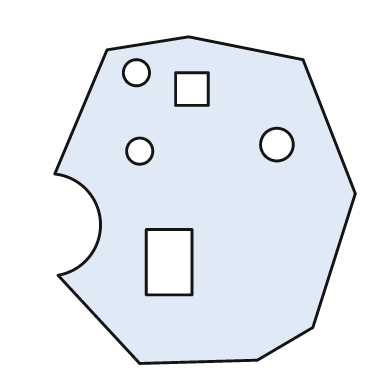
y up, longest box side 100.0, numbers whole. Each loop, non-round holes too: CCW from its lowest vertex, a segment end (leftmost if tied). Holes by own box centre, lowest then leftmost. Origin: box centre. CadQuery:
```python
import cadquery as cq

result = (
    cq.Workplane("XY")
    .moveTo(-20.0, -50.0)
    .lineTo(16.0, -49.0)
    .lineTo(33.0, -39.0)
    .lineTo(46.0, 2.0)
    .lineTo(30.0, 43.0)
    .lineTo(-5.0, 50.0)
    .lineTo(-30.0, 46.0)
    .lineTo(-46.0, 8.0)
    .threePointArc((-32.0, -7.0), (-45.0, -23.0))
    .close()
    .moveTo(-18.0, -29.0)
    .lineTo(-4.0, -29.0)
    .lineTo(-4.0, -9.0)
    .lineTo(-18.0, -9.0)
    .close()
    .moveTo(-20.0, 15.0)
    .circle(4.0)
    .moveTo(22.0, 17.0)
    .circle(5.0)
    .moveTo(-9.0, 29.0)
    .lineTo(1.0, 29.0)
    .lineTo(1.0, 39.0)
    .lineTo(-9.0, 39.0)
    .close()
    .moveTo(-21.0, 39.0)
    .circle(4.0)
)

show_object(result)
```